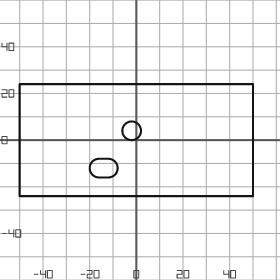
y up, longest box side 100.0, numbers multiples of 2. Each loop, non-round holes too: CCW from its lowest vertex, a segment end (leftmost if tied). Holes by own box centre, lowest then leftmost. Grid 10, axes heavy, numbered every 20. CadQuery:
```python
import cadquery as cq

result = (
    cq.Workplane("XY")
    .moveTo(-50.0, -24.0)
    .lineTo(50.0, -24.0)
    .lineTo(50.0, 24.0)
    .lineTo(-50.0, 24.0)
    .close()
    .moveTo(-16.0, -16.0)
    .lineTo(-12.0, -16.0)
    .threePointArc((-8.0, -12.0), (-12.0, -8.0))
    .lineTo(-16.0, -8.0)
    .threePointArc((-20.0, -12.0), (-16.0, -16.0))
    .close()
    .moveTo(-2.0, 4.0)
    .circle(4.0)
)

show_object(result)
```